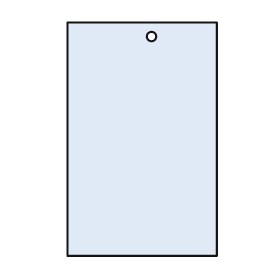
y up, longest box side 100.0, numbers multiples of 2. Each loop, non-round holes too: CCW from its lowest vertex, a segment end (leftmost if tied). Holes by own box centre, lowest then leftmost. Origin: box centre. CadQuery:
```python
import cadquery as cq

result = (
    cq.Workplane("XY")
    .moveTo(-32.0, -50.0)
    .lineTo(32.0, -50.0)
    .lineTo(32.0, 50.0)
    .lineTo(-32.0, 50.0)
    .close()
    .moveTo(4.0, 44.0)
    .circle(2.0)
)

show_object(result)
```